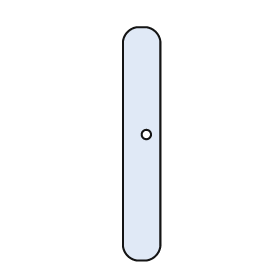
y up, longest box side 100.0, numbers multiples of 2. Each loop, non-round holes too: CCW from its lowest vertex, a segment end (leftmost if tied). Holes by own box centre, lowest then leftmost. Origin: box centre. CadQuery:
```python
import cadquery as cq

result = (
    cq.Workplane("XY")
    .moveTo(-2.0, -50.0)
    .lineTo(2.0, -50.0)
    .threePointArc((6.0, -48.0), (8.0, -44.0))
    .lineTo(8.0, 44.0)
    .threePointArc((6.0, 48.0), (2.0, 50.0))
    .lineTo(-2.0, 50.0)
    .threePointArc((-6.0, 48.0), (-8.0, 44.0))
    .lineTo(-8.0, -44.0)
    .threePointArc((-6.0, -48.0), (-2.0, -50.0))
    .close()
    .moveTo(2.0, 4.0)
    .circle(2.0)
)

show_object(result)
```